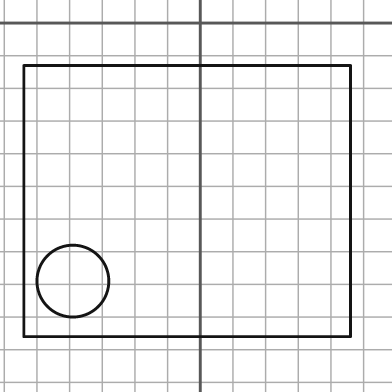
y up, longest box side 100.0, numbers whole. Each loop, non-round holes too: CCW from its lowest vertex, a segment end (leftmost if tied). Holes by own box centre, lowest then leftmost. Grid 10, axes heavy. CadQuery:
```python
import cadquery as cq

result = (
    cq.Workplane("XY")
    .moveTo(-54.0, -96.0)
    .lineTo(46.0, -96.0)
    .lineTo(46.0, -13.0)
    .lineTo(-54.0, -13.0)
    .close()
    .moveTo(-39.0, -79.0)
    .circle(11.0)
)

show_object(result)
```